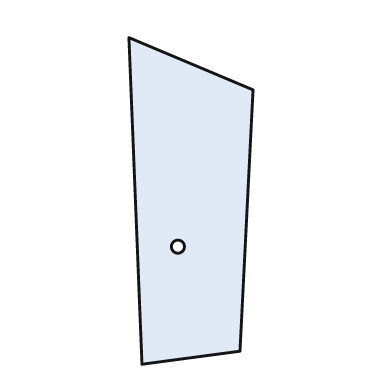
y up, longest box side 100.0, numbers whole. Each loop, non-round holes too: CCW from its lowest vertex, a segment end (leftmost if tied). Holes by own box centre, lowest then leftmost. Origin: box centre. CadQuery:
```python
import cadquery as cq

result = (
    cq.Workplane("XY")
    .moveTo(-15.0, -50.0)
    .lineTo(15.0, -46.0)
    .lineTo(19.0, 34.0)
    .lineTo(-19.0, 50.0)
    .close()
    .moveTo(-4.0, -14.0)
    .circle(2.0)
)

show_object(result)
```